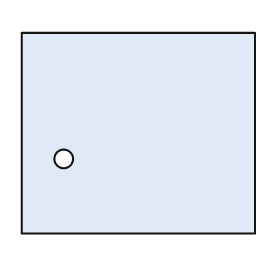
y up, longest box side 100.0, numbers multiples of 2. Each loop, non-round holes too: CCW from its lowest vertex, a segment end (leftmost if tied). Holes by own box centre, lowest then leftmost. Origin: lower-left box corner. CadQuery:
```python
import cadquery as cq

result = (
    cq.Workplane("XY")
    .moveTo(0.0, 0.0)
    .lineTo(100.0, 0.0)
    .lineTo(100.0, 86.0)
    .lineTo(0.0, 86.0)
    .close()
    .moveTo(18.0, 32.0)
    .circle(4.0)
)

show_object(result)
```